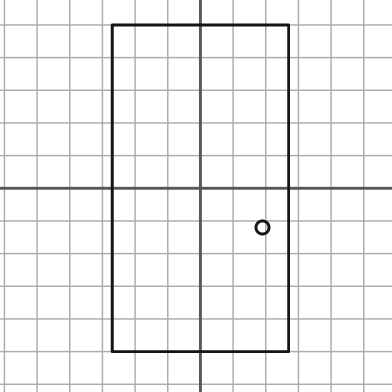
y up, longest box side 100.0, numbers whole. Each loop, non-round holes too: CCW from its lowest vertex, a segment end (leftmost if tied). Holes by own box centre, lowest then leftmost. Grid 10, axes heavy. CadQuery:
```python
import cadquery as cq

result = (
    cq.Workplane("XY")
    .moveTo(-27.0, -50.0)
    .lineTo(27.0, -50.0)
    .lineTo(27.0, 50.0)
    .lineTo(-27.0, 50.0)
    .close()
    .moveTo(19.0, -12.0)
    .circle(2.0)
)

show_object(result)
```